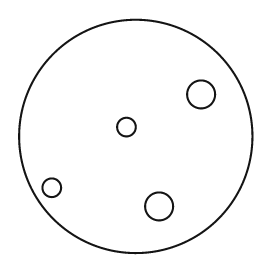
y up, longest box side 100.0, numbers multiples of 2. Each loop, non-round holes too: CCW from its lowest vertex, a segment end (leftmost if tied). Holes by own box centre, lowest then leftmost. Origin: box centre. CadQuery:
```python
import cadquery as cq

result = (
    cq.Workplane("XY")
    .moveTo(0.0, 0.0)
    .circle(50.0)
    .moveTo(10.0, -30.0)
    .circle(6.0)
    .moveTo(-36.0, -22.0)
    .circle(4.0)
    .moveTo(-4.0, 4.0)
    .circle(4.0)
    .moveTo(28.0, 18.0)
    .circle(6.0)
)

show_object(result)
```